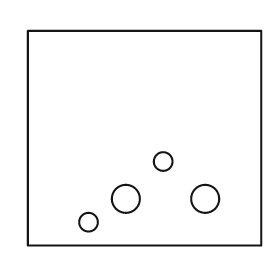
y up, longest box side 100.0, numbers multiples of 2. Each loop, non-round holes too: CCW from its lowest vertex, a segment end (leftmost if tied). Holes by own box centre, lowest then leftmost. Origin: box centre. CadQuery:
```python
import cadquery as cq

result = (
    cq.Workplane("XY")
    .moveTo(-50.0, -46.0)
    .lineTo(50.0, -46.0)
    .lineTo(50.0, 46.0)
    .lineTo(-50.0, 46.0)
    .close()
    .moveTo(-24.0, -36.0)
    .circle(4.0)
    .moveTo(-8.0, -26.0)
    .circle(6.0)
    .moveTo(26.0, -26.0)
    .circle(6.0)
    .moveTo(8.0, -10.0)
    .circle(4.0)
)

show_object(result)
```